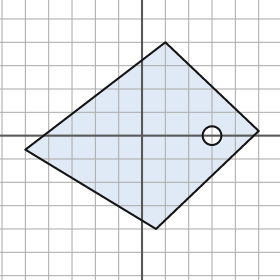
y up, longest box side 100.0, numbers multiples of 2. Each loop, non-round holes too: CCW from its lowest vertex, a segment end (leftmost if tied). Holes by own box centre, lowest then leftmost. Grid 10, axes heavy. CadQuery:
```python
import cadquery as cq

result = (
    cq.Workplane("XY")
    .moveTo(6.0, -40.0)
    .lineTo(50.0, 2.0)
    .lineTo(10.0, 40.0)
    .lineTo(-50.0, -6.0)
    .close()
    .moveTo(30.0, 0.0)
    .circle(4.0)
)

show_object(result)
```